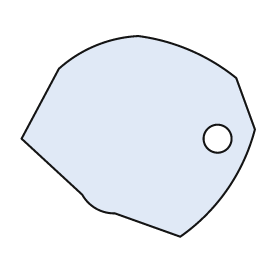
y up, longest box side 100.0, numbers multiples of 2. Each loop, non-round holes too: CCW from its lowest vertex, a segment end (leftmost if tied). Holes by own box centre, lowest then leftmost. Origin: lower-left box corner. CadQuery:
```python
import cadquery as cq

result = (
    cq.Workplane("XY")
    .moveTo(68.0, 0.0)
    .threePointArc((88.0, 20.0), (100.0, 46.0))
    .lineTo(92.0, 68.0)
    .threePointArc((72.0, 80.0), (50.0, 86.0))
    .threePointArc((32.0, 82.0), (16.0, 72.0))
    .lineTo(0.0, 42.0)
    .lineTo(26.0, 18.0)
    .threePointArc((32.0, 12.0), (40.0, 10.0))
    .close()
    .moveTo(84.0, 42.0)
    .circle(6.0)
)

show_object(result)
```